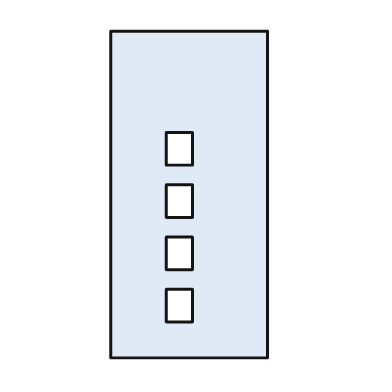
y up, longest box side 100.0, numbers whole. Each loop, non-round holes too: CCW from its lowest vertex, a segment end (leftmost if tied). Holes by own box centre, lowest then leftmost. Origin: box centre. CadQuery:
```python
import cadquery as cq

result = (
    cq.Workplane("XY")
    .moveTo(-24.0, -50.0)
    .lineTo(24.0, -50.0)
    .lineTo(24.0, 50.0)
    .lineTo(-24.0, 50.0)
    .close()
    .moveTo(-7.0, -39.0)
    .lineTo(1.0, -39.0)
    .lineTo(1.0, -29.0)
    .lineTo(-7.0, -29.0)
    .close()
    .moveTo(-7.0, -23.0)
    .lineTo(1.0, -23.0)
    .lineTo(1.0, -13.0)
    .lineTo(-7.0, -13.0)
    .close()
    .moveTo(-7.0, -7.0)
    .lineTo(1.0, -7.0)
    .lineTo(1.0, 3.0)
    .lineTo(-7.0, 3.0)
    .close()
    .moveTo(-7.0, 9.0)
    .lineTo(1.0, 9.0)
    .lineTo(1.0, 19.0)
    .lineTo(-7.0, 19.0)
    .close()
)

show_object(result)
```